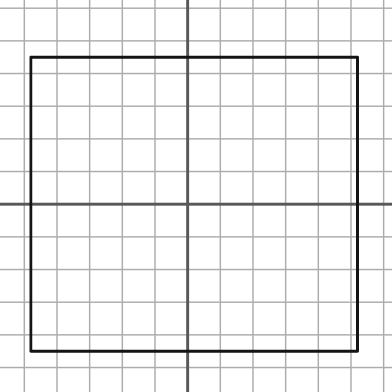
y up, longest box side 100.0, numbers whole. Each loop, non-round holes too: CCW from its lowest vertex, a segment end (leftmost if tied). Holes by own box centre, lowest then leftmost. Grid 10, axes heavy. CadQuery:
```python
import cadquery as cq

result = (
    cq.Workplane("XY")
    .moveTo(-48.0, -45.0)
    .lineTo(52.0, -45.0)
    .lineTo(52.0, 45.0)
    .lineTo(-48.0, 45.0)
    .close()
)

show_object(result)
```